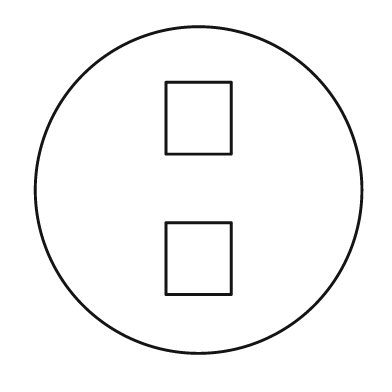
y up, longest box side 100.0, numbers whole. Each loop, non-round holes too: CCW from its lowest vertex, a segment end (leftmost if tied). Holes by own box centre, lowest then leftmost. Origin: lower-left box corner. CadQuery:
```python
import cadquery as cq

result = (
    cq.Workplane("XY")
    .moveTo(50.0, 50.0)
    .circle(50.0)
    .moveTo(40.0, 18.0)
    .lineTo(60.0, 18.0)
    .lineTo(60.0, 40.0)
    .lineTo(40.0, 40.0)
    .close()
    .moveTo(40.0, 61.0)
    .lineTo(60.0, 61.0)
    .lineTo(60.0, 83.0)
    .lineTo(40.0, 83.0)
    .close()
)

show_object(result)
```